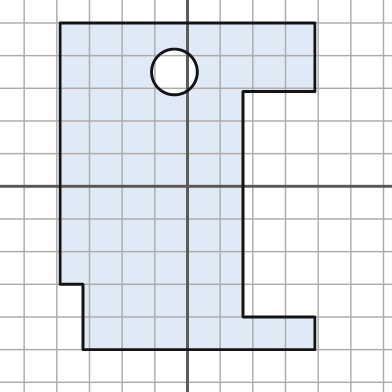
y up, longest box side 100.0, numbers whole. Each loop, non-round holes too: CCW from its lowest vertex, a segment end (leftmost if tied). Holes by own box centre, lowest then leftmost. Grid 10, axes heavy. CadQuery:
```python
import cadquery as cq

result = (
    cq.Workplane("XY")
    .moveTo(-32.0, -50.0)
    .lineTo(39.0, -50.0)
    .lineTo(39.0, -40.0)
    .lineTo(17.0, -40.0)
    .lineTo(17.0, 29.0)
    .lineTo(39.0, 29.0)
    .lineTo(39.0, 50.0)
    .lineTo(-39.0, 50.0)
    .lineTo(-39.0, -30.0)
    .lineTo(-32.0, -30.0)
    .close()
    .moveTo(-4.0, 35.0)
    .circle(7.0)
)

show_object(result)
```